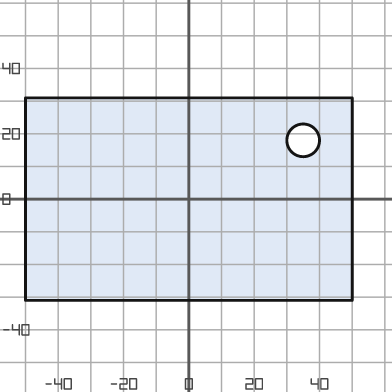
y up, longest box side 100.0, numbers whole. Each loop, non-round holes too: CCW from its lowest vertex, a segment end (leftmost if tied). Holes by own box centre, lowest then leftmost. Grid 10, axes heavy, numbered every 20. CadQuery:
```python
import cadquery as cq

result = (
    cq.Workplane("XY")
    .moveTo(-50.0, -31.0)
    .lineTo(50.0, -31.0)
    .lineTo(50.0, 31.0)
    .lineTo(-50.0, 31.0)
    .close()
    .moveTo(35.0, 18.0)
    .circle(5.0)
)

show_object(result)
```